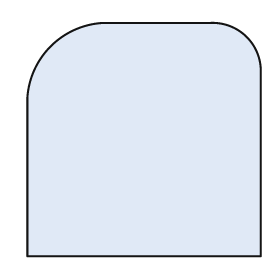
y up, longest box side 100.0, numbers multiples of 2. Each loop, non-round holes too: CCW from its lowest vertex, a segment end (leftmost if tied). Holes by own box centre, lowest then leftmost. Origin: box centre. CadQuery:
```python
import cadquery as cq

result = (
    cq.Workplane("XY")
    .moveTo(-50.0, -50.0)
    .lineTo(50.0, -50.0)
    .lineTo(50.0, 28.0)
    .threePointArc((44.0, 44.0), (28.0, 50.0))
    .lineTo(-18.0, 50.0)
    .threePointArc((-40.0, 40.0), (-50.0, 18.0))
    .close()
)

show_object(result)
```